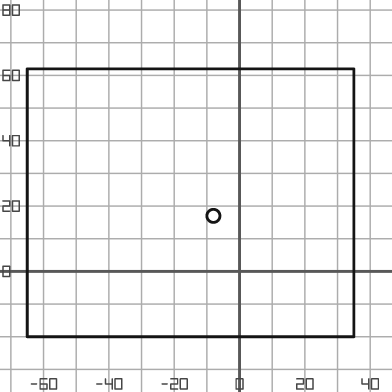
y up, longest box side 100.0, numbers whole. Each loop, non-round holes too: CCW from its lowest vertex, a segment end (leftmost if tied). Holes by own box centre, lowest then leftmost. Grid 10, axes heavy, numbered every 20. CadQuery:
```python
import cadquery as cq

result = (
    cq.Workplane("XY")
    .moveTo(-65.0, -20.0)
    .lineTo(35.0, -20.0)
    .lineTo(35.0, 62.0)
    .lineTo(-65.0, 62.0)
    .close()
    .moveTo(-8.0, 17.0)
    .circle(2.0)
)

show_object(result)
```